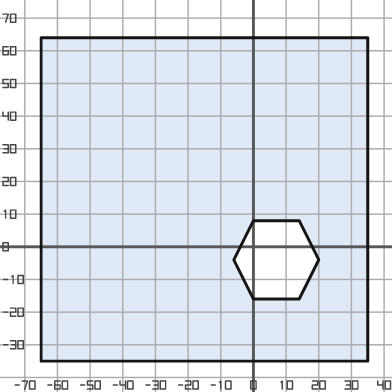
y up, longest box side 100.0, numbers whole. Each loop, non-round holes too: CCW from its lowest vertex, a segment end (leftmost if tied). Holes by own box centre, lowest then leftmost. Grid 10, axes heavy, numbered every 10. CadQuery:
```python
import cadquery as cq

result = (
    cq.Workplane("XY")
    .moveTo(-65.0, -35.0)
    .lineTo(35.0, -35.0)
    .lineTo(35.0, 64.0)
    .lineTo(-65.0, 64.0)
    .close()
    .moveTo(0.0, -16.0)
    .lineTo(14.0, -16.0)
    .lineTo(20.0, -4.0)
    .lineTo(14.0, 8.0)
    .lineTo(0.0, 8.0)
    .lineTo(-6.0, -4.0)
    .close()
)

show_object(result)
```